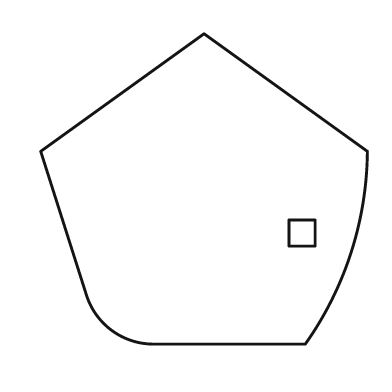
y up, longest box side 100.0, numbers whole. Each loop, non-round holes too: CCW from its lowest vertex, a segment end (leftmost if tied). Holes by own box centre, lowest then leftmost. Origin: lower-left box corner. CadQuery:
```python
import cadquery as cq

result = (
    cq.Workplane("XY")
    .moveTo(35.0, 0.0)
    .lineTo(81.0, 0.0)
    .threePointArc((95.0, 28.0), (100.0, 59.0))
    .lineTo(50.0, 95.0)
    .lineTo(0.0, 59.0)
    .lineTo(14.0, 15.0)
    .threePointArc((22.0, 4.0), (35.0, 0.0))
    .close()
    .moveTo(76.0, 30.0)
    .lineTo(84.0, 30.0)
    .lineTo(84.0, 38.0)
    .lineTo(76.0, 38.0)
    .close()
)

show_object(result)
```